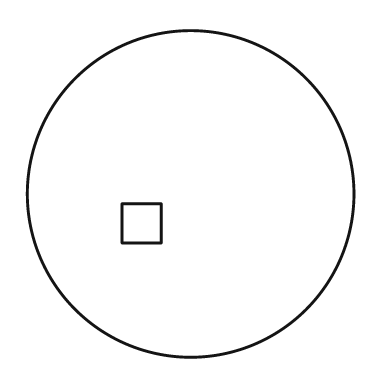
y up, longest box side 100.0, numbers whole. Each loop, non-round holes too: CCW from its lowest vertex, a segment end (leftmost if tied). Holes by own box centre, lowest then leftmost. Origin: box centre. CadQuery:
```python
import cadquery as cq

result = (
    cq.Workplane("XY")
    .moveTo(0.0, 0.0)
    .circle(50.0)
    .moveTo(-21.0, -15.0)
    .lineTo(-9.0, -15.0)
    .lineTo(-9.0, -3.0)
    .lineTo(-21.0, -3.0)
    .close()
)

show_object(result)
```